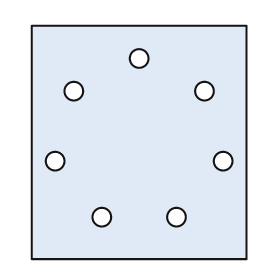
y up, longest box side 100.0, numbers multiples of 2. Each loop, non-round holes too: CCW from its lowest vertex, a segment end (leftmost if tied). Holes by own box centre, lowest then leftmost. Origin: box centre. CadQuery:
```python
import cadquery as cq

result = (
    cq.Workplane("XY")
    .moveTo(-46.0, -50.0)
    .lineTo(46.0, -50.0)
    .lineTo(46.0, 50.0)
    .lineTo(-46.0, 50.0)
    .close()
    .moveTo(-16.0, -32.0)
    .circle(4.0)
    .moveTo(16.0, -32.0)
    .circle(4.0)
    .moveTo(-36.0, -8.0)
    .circle(4.0)
    .moveTo(36.0, -8.0)
    .circle(4.0)
    .moveTo(-28.0, 22.0)
    .circle(4.0)
    .moveTo(28.0, 22.0)
    .circle(4.0)
    .moveTo(0.0, 36.0)
    .circle(4.0)
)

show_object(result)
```